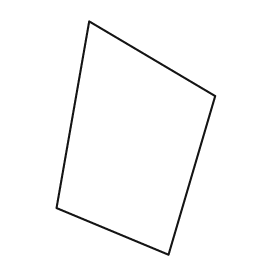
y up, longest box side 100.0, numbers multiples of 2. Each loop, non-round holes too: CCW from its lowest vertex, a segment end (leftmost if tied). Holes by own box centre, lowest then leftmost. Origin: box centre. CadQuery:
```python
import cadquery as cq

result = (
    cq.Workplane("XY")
    .moveTo(14.0, -50.0)
    .lineTo(34.0, 18.0)
    .lineTo(-20.0, 50.0)
    .lineTo(-34.0, -30.0)
    .close()
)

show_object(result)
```